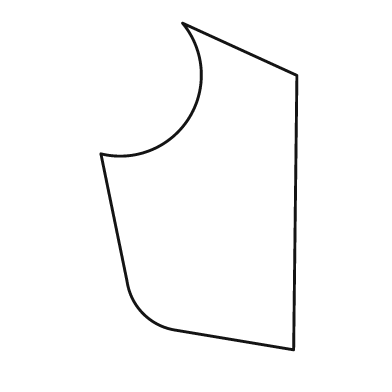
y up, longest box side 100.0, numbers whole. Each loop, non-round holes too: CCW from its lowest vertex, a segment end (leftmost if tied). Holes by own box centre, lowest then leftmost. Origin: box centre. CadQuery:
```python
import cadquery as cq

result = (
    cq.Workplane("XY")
    .moveTo(29.0, -50.0)
    .lineTo(30.0, 34.0)
    .lineTo(-5.0, 50.0)
    .threePointArc((-3.0, 21.0), (-30.0, 10.0))
    .lineTo(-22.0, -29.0)
    .threePointArc((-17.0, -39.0), (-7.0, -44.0))
    .close()
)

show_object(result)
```